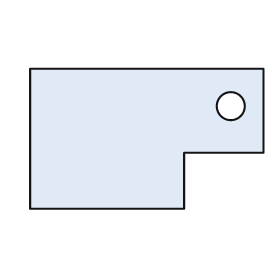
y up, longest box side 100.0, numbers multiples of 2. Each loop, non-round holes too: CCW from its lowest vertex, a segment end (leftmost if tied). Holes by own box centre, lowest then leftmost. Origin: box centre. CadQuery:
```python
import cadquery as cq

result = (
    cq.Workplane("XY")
    .moveTo(-50.0, -30.0)
    .lineTo(16.0, -30.0)
    .lineTo(16.0, -6.0)
    .lineTo(50.0, -6.0)
    .lineTo(50.0, 30.0)
    .lineTo(-50.0, 30.0)
    .close()
    .moveTo(36.0, 14.0)
    .circle(6.0)
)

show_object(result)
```